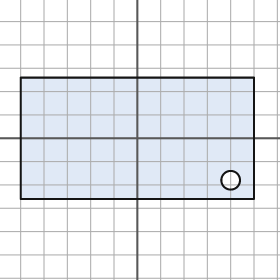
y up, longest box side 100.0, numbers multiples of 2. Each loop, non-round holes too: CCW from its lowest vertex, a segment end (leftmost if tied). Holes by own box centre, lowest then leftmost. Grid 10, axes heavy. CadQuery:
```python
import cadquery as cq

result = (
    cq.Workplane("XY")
    .moveTo(-50.0, -26.0)
    .lineTo(50.0, -26.0)
    .lineTo(50.0, 26.0)
    .lineTo(-50.0, 26.0)
    .close()
    .moveTo(40.0, -18.0)
    .circle(4.0)
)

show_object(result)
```